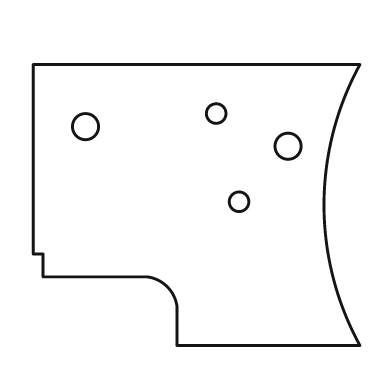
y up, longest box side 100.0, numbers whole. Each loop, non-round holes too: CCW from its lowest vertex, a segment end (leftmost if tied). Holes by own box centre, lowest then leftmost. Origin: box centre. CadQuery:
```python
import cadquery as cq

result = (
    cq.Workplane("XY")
    .moveTo(-6.0, -43.0)
    .lineTo(50.0, -43.0)
    .threePointArc((39.0, 0.0), (50.0, 43.0))
    .lineTo(-50.0, 43.0)
    .lineTo(-50.0, -15.0)
    .lineTo(-47.0, -15.0)
    .lineTo(-47.0, -22.0)
    .lineTo(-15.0, -22.0)
    .threePointArc((-9.0, -25.0), (-6.0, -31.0))
    .close()
    .moveTo(13.0, 1.0)
    .circle(3.0)
    .moveTo(28.0, 18.0)
    .circle(4.0)
    .moveTo(-34.0, 24.0)
    .circle(4.0)
    .moveTo(6.0, 28.0)
    .circle(3.0)
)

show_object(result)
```